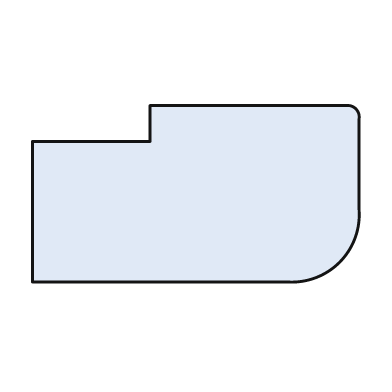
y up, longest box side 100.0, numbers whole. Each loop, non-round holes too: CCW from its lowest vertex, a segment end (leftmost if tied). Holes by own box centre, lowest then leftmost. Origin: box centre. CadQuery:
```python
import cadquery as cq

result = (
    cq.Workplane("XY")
    .moveTo(-50.0, -27.0)
    .lineTo(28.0, -27.0)
    .threePointArc((44.0, -21.0), (50.0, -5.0))
    .lineTo(50.0, 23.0)
    .threePointArc((49.0, 26.0), (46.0, 27.0))
    .lineTo(-14.0, 27.0)
    .lineTo(-14.0, 16.0)
    .lineTo(-50.0, 16.0)
    .close()
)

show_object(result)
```